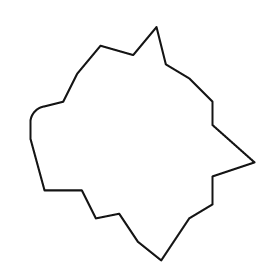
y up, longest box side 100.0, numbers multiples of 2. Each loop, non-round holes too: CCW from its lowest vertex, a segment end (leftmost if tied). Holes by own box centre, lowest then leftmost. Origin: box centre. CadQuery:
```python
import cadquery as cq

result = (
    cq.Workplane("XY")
    .moveTo(8.0, -50.0)
    .lineTo(20.0, -32.0)
    .lineTo(30.0, -26.0)
    .lineTo(30.0, -14.0)
    .lineTo(48.0, -8.0)
    .lineTo(30.0, 8.0)
    .lineTo(30.0, 18.0)
    .lineTo(20.0, 28.0)
    .lineTo(10.0, 34.0)
    .lineTo(6.0, 50.0)
    .lineTo(-4.0, 38.0)
    .lineTo(-18.0, 42.0)
    .lineTo(-28.0, 30.0)
    .lineTo(-34.0, 18.0)
    .lineTo(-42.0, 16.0)
    .threePointArc((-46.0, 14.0), (-48.0, 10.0))
    .lineTo(-48.0, 2.0)
    .lineTo(-42.0, -20.0)
    .lineTo(-26.0, -20.0)
    .lineTo(-20.0, -32.0)
    .lineTo(-10.0, -30.0)
    .lineTo(-2.0, -42.0)
    .close()
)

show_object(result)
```